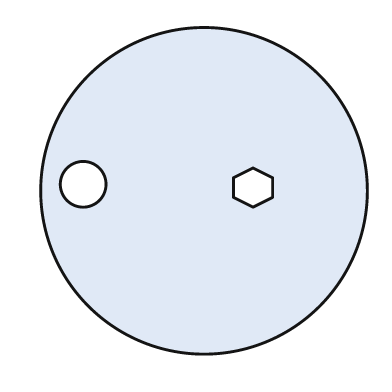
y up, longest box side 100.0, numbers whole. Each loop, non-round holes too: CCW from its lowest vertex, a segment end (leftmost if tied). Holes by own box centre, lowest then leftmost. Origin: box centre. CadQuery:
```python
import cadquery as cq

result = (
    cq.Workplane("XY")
    .moveTo(0.0, 0.0)
    .circle(50.0)
    .moveTo(15.0, -5.0)
    .lineTo(21.0, -2.0)
    .lineTo(21.0, 4.0)
    .lineTo(15.0, 7.0)
    .lineTo(9.0, 4.0)
    .lineTo(9.0, -2.0)
    .close()
    .moveTo(-37.0, 2.0)
    .circle(7.0)
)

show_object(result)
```